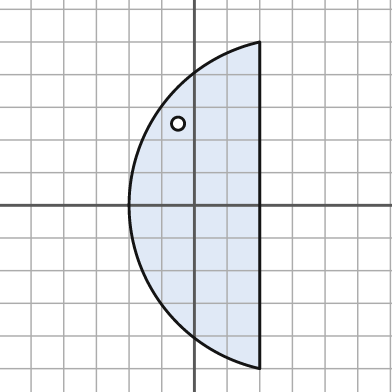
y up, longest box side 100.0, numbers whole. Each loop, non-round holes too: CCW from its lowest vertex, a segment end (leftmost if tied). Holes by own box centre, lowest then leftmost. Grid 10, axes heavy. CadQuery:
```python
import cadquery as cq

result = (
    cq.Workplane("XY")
    .moveTo(20.0, -50.0)
    .lineTo(20.0, 50.0)
    .threePointArc((-20.0, 0.0), (20.0, -50.0))
    .close()
    .moveTo(-5.0, 25.0)
    .circle(2.0)
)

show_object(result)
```